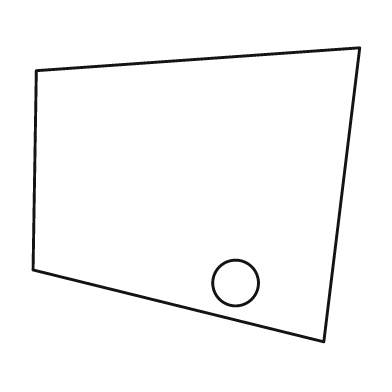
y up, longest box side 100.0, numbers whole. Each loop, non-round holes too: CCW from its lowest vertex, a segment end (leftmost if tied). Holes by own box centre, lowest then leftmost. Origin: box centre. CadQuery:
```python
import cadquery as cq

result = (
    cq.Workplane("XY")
    .moveTo(39.0, -45.0)
    .lineTo(50.0, 45.0)
    .lineTo(-49.0, 38.0)
    .lineTo(-50.0, -23.0)
    .close()
    .moveTo(12.0, -27.0)
    .circle(7.0)
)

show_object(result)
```